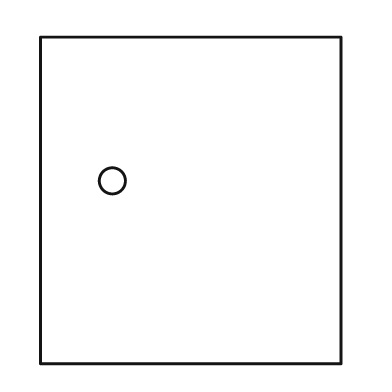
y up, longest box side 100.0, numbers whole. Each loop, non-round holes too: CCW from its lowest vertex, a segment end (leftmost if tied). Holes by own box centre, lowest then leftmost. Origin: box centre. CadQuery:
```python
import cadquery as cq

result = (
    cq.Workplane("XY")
    .moveTo(-46.0, -50.0)
    .lineTo(46.0, -50.0)
    .lineTo(46.0, 50.0)
    .lineTo(-46.0, 50.0)
    .close()
    .moveTo(-24.0, 6.0)
    .circle(4.0)
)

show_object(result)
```